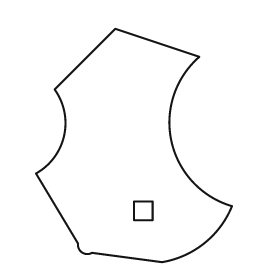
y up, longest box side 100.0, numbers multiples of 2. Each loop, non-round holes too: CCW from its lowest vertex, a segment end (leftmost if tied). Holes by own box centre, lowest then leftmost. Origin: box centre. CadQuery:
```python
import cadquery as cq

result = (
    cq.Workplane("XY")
    .moveTo(12.0, -50.0)
    .threePointArc((30.0, -42.0), (42.0, -26.0))
    .threePointArc((16.0, 2.0), (28.0, 38.0))
    .lineTo(-8.0, 50.0)
    .lineTo(-34.0, 24.0)
    .threePointArc((-30.0, 4.0), (-42.0, -12.0))
    .lineTo(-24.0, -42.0)
    .threePointArc((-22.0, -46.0), (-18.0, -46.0))
    .close()
    .moveTo(0.0, -32.0)
    .lineTo(8.0, -32.0)
    .lineTo(8.0, -24.0)
    .lineTo(0.0, -24.0)
    .close()
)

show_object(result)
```